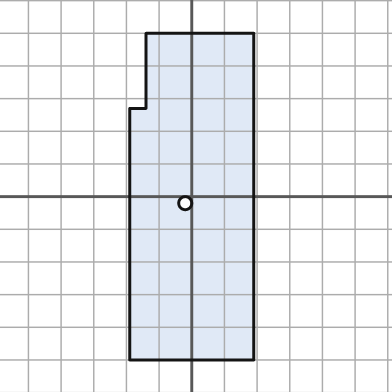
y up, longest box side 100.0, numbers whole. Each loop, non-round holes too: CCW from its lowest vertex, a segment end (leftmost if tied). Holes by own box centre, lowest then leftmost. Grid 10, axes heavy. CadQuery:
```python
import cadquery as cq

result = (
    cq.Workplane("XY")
    .moveTo(-19.0, -50.0)
    .lineTo(19.0, -50.0)
    .lineTo(19.0, 50.0)
    .lineTo(-14.0, 50.0)
    .lineTo(-14.0, 27.0)
    .lineTo(-19.0, 27.0)
    .close()
    .moveTo(-2.0, -2.0)
    .circle(2.0)
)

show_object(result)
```